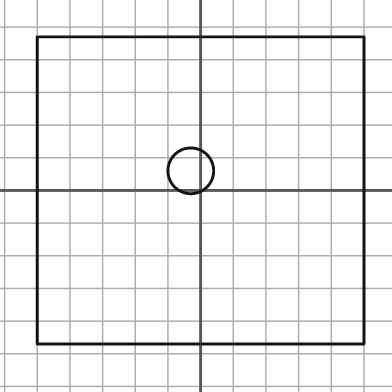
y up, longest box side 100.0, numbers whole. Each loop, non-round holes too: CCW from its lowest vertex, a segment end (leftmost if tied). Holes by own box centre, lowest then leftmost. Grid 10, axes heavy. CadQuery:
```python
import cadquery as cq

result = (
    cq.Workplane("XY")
    .moveTo(-50.0, -47.0)
    .lineTo(50.0, -47.0)
    .lineTo(50.0, 47.0)
    .lineTo(-50.0, 47.0)
    .close()
    .moveTo(-3.0, 6.0)
    .circle(7.0)
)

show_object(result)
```